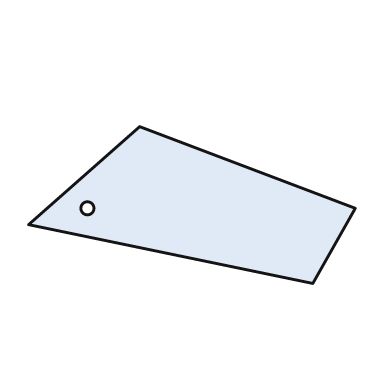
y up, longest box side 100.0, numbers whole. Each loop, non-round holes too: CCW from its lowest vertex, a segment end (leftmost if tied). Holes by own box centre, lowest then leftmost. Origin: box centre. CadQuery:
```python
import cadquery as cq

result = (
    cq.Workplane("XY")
    .moveTo(37.0, -24.0)
    .lineTo(50.0, -1.0)
    .lineTo(-16.0, 24.0)
    .lineTo(-50.0, -6.0)
    .close()
    .moveTo(-32.0, -1.0)
    .circle(2.0)
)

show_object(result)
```